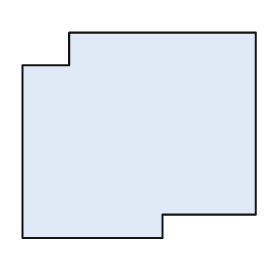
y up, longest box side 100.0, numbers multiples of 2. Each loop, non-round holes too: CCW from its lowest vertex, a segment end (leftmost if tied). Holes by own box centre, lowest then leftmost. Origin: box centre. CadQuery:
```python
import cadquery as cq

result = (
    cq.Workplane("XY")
    .moveTo(-50.0, -44.0)
    .lineTo(10.0, -44.0)
    .lineTo(10.0, -34.0)
    .lineTo(50.0, -34.0)
    .lineTo(50.0, 44.0)
    .lineTo(-30.0, 44.0)
    .lineTo(-30.0, 30.0)
    .lineTo(-50.0, 30.0)
    .close()
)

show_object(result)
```